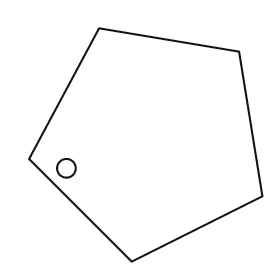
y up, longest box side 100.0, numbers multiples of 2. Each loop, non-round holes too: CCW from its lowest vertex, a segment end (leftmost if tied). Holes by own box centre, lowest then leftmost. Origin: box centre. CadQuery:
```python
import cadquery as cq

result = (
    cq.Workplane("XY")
    .moveTo(-6.0, -50.0)
    .lineTo(50.0, -22.0)
    .lineTo(40.0, 40.0)
    .lineTo(-20.0, 50.0)
    .lineTo(-50.0, -6.0)
    .close()
    .moveTo(-34.0, -10.0)
    .circle(4.0)
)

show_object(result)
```